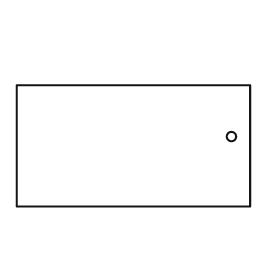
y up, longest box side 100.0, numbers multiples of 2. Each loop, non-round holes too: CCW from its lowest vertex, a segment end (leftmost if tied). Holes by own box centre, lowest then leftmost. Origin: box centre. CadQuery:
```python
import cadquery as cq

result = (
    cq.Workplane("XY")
    .moveTo(-50.0, -26.0)
    .lineTo(50.0, -26.0)
    .lineTo(50.0, 26.0)
    .lineTo(-50.0, 26.0)
    .close()
    .moveTo(42.0, 4.0)
    .circle(2.0)
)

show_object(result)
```